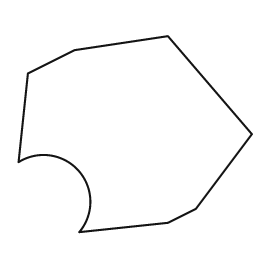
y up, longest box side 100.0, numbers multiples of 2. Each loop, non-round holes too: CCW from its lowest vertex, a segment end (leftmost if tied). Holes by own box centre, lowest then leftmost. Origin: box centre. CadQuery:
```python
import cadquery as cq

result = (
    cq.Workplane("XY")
    .moveTo(-24.0, -42.0)
    .lineTo(14.0, -38.0)
    .lineTo(26.0, -32.0)
    .lineTo(50.0, 0.0)
    .lineTo(14.0, 42.0)
    .lineTo(-26.0, 36.0)
    .lineTo(-46.0, 26.0)
    .lineTo(-50.0, -12.0)
    .threePointArc((-24.0, -16.0), (-24.0, -42.0))
    .close()
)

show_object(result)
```